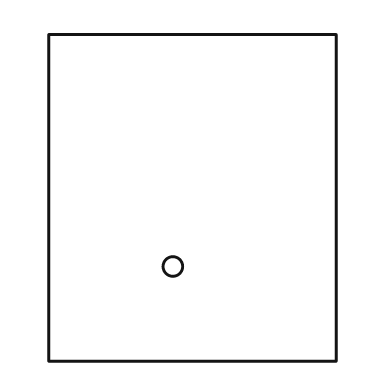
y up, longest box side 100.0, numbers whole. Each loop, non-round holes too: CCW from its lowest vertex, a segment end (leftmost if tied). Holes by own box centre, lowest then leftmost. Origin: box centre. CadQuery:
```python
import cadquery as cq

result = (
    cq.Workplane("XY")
    .moveTo(-44.0, -50.0)
    .lineTo(44.0, -50.0)
    .lineTo(44.0, 50.0)
    .lineTo(-44.0, 50.0)
    .close()
    .moveTo(-6.0, -21.0)
    .circle(3.0)
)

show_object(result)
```